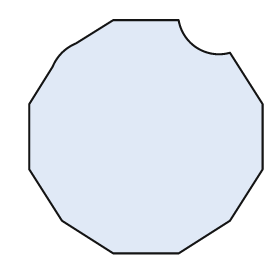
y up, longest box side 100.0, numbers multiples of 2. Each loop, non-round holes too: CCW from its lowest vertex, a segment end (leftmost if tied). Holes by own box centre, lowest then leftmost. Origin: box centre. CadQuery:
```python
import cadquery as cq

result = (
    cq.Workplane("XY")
    .moveTo(-14.0, -50.0)
    .lineTo(14.0, -50.0)
    .lineTo(36.0, -36.0)
    .lineTo(50.0, -14.0)
    .lineTo(50.0, 14.0)
    .lineTo(36.0, 36.0)
    .threePointArc((22.0, 38.0), (14.0, 50.0))
    .lineTo(-14.0, 50.0)
    .lineTo(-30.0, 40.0)
    .threePointArc((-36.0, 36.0), (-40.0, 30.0))
    .lineTo(-50.0, 14.0)
    .lineTo(-50.0, -14.0)
    .lineTo(-36.0, -36.0)
    .close()
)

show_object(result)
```